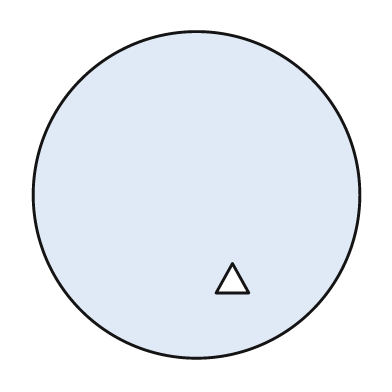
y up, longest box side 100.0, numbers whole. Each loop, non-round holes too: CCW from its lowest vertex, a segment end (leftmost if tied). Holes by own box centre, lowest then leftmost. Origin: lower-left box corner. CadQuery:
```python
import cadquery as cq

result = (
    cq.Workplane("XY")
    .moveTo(50.0, 50.0)
    .circle(50.0)
    .moveTo(56.0, 20.0)
    .lineTo(66.0, 20.0)
    .lineTo(61.0, 29.0)
    .close()
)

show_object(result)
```